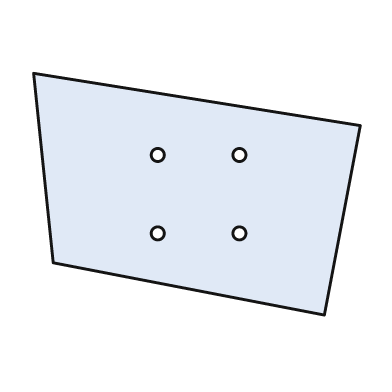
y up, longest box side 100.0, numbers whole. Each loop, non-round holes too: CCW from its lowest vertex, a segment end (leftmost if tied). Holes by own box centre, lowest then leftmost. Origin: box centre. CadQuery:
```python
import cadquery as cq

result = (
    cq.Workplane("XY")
    .moveTo(39.0, -37.0)
    .lineTo(50.0, 21.0)
    .lineTo(-50.0, 37.0)
    .lineTo(-44.0, -21.0)
    .close()
    .moveTo(-12.0, -12.0)
    .circle(2.0)
    .moveTo(13.0, -12.0)
    .circle(2.0)
    .moveTo(-12.0, 12.0)
    .circle(2.0)
    .moveTo(13.0, 12.0)
    .circle(2.0)
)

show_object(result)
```